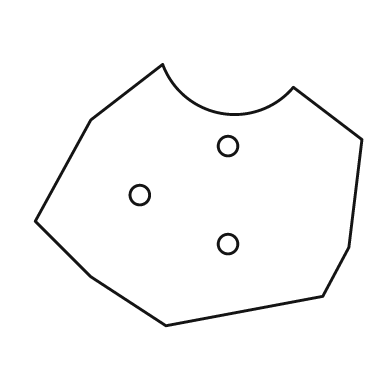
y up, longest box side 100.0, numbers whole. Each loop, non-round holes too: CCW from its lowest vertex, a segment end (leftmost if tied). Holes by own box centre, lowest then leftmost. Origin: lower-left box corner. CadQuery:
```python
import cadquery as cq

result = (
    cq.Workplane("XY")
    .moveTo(40.0, 0.0)
    .lineTo(88.0, 9.0)
    .lineTo(96.0, 24.0)
    .lineTo(100.0, 57.0)
    .lineTo(79.0, 73.0)
    .threePointArc((57.0, 65.0), (39.0, 80.0))
    .lineTo(17.0, 63.0)
    .lineTo(0.0, 32.0)
    .lineTo(17.0, 15.0)
    .close()
    .moveTo(59.0, 25.0)
    .circle(3.0)
    .moveTo(32.0, 40.0)
    .circle(3.0)
    .moveTo(59.0, 55.0)
    .circle(3.0)
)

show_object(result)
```